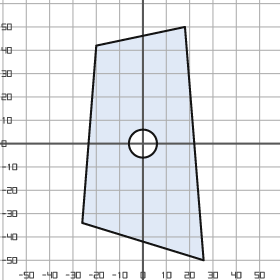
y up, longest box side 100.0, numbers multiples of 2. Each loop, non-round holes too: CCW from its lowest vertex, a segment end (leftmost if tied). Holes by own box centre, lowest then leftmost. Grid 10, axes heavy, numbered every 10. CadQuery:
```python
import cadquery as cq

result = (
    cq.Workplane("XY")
    .moveTo(26.0, -50.0)
    .lineTo(18.0, 50.0)
    .lineTo(-20.0, 42.0)
    .lineTo(-26.0, -34.0)
    .close()
    .moveTo(0.0, 0.0)
    .circle(6.0)
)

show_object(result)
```